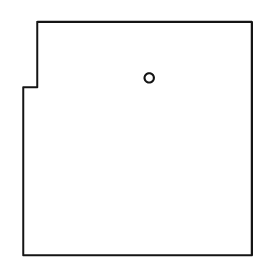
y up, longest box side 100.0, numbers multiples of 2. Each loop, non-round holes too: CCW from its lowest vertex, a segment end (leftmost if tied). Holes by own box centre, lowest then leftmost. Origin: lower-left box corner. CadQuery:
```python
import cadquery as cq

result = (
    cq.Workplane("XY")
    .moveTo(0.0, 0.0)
    .lineTo(98.0, 0.0)
    .lineTo(98.0, 100.0)
    .lineTo(6.0, 100.0)
    .lineTo(6.0, 72.0)
    .lineTo(0.0, 72.0)
    .close()
    .moveTo(54.0, 76.0)
    .circle(2.0)
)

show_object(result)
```